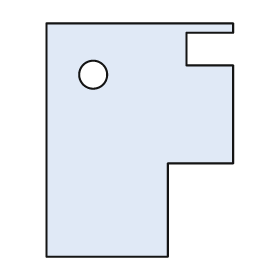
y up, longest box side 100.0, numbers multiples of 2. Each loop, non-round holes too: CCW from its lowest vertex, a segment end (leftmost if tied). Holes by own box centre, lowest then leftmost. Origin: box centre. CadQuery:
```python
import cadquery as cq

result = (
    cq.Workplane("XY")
    .moveTo(-40.0, -50.0)
    .lineTo(12.0, -50.0)
    .lineTo(12.0, -10.0)
    .lineTo(40.0, -10.0)
    .lineTo(40.0, 32.0)
    .lineTo(20.0, 32.0)
    .lineTo(20.0, 46.0)
    .lineTo(40.0, 46.0)
    .lineTo(40.0, 50.0)
    .lineTo(-40.0, 50.0)
    .close()
    .moveTo(-20.0, 28.0)
    .circle(6.0)
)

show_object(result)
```